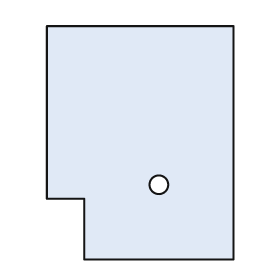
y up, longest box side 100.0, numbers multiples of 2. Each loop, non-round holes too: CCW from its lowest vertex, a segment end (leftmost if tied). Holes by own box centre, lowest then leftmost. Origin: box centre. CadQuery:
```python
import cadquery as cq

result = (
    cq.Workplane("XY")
    .moveTo(-24.0, -50.0)
    .lineTo(40.0, -50.0)
    .lineTo(40.0, 50.0)
    .lineTo(-40.0, 50.0)
    .lineTo(-40.0, -24.0)
    .lineTo(-24.0, -24.0)
    .close()
    .moveTo(8.0, -18.0)
    .circle(4.0)
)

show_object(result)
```